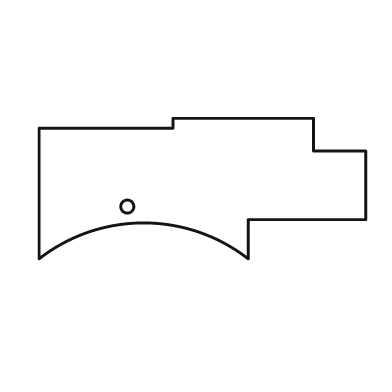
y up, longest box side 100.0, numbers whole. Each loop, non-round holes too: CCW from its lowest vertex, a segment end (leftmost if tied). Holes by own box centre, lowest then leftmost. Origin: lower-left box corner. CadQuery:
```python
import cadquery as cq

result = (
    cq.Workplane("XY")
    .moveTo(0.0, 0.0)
    .threePointArc((32.0, 11.0), (64.0, 0.0))
    .lineTo(64.0, 12.0)
    .lineTo(100.0, 12.0)
    .lineTo(100.0, 33.0)
    .lineTo(84.0, 33.0)
    .lineTo(84.0, 43.0)
    .lineTo(41.0, 43.0)
    .lineTo(41.0, 40.0)
    .lineTo(0.0, 40.0)
    .close()
    .moveTo(27.0, 16.0)
    .circle(2.0)
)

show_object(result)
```